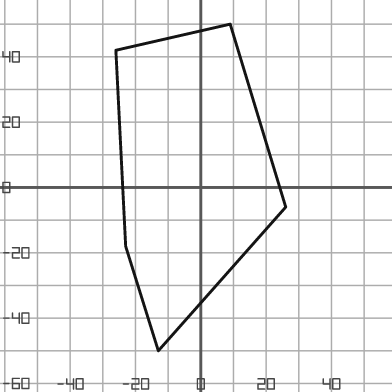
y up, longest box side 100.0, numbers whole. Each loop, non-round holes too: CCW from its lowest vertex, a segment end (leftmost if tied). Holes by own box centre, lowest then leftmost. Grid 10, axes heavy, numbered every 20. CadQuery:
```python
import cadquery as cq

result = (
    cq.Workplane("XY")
    .moveTo(-13.0, -50.0)
    .lineTo(26.0, -6.0)
    .lineTo(9.0, 50.0)
    .lineTo(-26.0, 42.0)
    .lineTo(-23.0, -18.0)
    .close()
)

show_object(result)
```